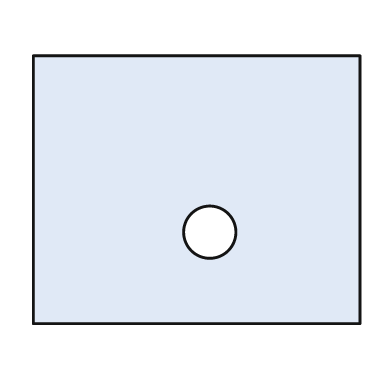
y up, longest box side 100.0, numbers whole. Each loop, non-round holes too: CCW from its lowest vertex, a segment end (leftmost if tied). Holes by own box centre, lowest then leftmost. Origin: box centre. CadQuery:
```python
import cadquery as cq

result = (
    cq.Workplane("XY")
    .moveTo(-50.0, -41.0)
    .lineTo(50.0, -41.0)
    .lineTo(50.0, 41.0)
    .lineTo(-50.0, 41.0)
    .close()
    .moveTo(4.0, -13.0)
    .circle(8.0)
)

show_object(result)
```